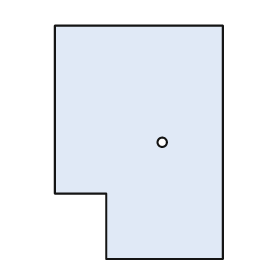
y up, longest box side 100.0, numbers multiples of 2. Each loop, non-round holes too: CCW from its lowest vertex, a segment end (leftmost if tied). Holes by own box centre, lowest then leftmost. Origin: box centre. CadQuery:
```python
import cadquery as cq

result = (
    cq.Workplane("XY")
    .moveTo(-14.0, -50.0)
    .lineTo(36.0, -50.0)
    .lineTo(36.0, 50.0)
    .lineTo(-36.0, 50.0)
    .lineTo(-36.0, -22.0)
    .lineTo(-14.0, -22.0)
    .close()
    .moveTo(10.0, 0.0)
    .circle(2.0)
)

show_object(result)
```